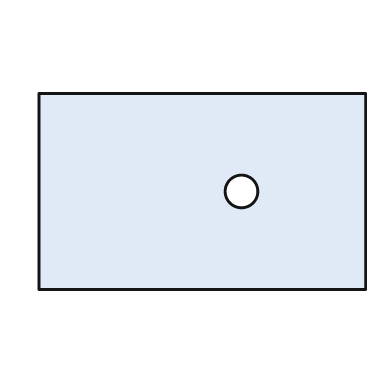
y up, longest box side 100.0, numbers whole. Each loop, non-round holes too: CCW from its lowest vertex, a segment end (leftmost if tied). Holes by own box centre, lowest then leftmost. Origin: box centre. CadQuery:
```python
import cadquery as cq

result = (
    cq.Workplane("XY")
    .moveTo(-50.0, -30.0)
    .lineTo(50.0, -30.0)
    .lineTo(50.0, 30.0)
    .lineTo(-50.0, 30.0)
    .close()
    .moveTo(12.0, 0.0)
    .circle(5.0)
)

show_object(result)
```